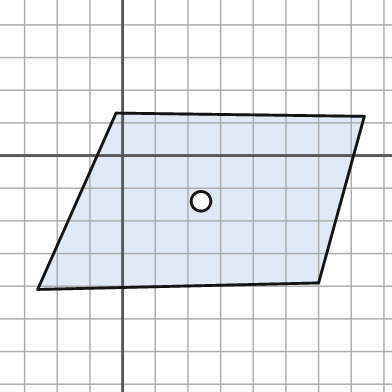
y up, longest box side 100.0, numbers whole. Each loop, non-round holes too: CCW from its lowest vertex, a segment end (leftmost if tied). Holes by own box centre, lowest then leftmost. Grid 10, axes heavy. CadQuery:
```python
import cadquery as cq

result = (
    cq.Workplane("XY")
    .moveTo(-26.0, -41.0)
    .lineTo(60.0, -39.0)
    .lineTo(74.0, 12.0)
    .lineTo(-2.0, 13.0)
    .close()
    .moveTo(24.0, -14.0)
    .circle(3.0)
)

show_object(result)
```